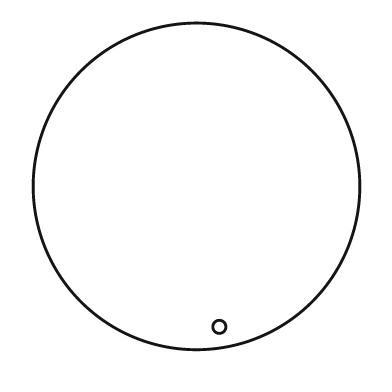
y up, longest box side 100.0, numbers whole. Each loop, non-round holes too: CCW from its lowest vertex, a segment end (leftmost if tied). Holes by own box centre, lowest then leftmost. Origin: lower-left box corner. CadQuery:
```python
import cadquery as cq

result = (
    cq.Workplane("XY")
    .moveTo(50.0, 50.0)
    .circle(50.0)
    .moveTo(57.0, 7.0)
    .circle(2.0)
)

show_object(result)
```